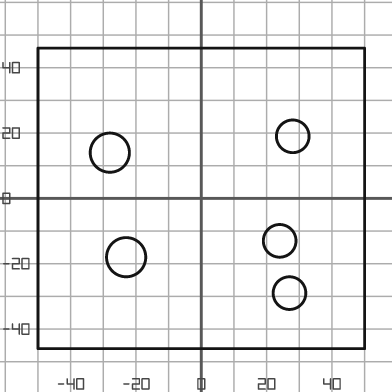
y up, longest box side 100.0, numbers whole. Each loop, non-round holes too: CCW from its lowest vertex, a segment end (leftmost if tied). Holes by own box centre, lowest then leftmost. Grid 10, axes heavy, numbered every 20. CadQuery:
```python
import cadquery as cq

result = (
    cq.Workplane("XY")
    .moveTo(-50.0, -46.0)
    .lineTo(50.0, -46.0)
    .lineTo(50.0, 46.0)
    .lineTo(-50.0, 46.0)
    .close()
    .moveTo(27.0, -29.0)
    .circle(5.0)
    .moveTo(-23.0, -18.0)
    .circle(6.0)
    .moveTo(24.0, -13.0)
    .circle(5.0)
    .moveTo(-28.0, 14.0)
    .circle(6.0)
    .moveTo(28.0, 19.0)
    .circle(5.0)
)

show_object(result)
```